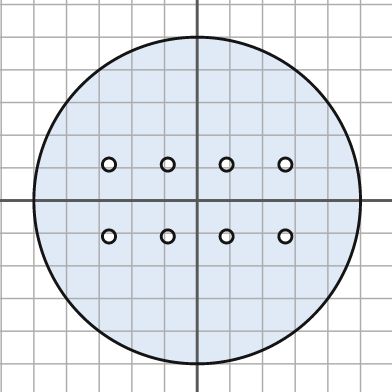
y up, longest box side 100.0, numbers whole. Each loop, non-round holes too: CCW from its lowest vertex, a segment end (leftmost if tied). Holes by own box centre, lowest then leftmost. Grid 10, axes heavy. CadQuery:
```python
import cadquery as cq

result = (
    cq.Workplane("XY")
    .moveTo(0.0, 0.0)
    .circle(50.0)
    .moveTo(-27.0, -11.0)
    .circle(2.0)
    .moveTo(-9.0, -11.0)
    .circle(2.0)
    .moveTo(9.0, -11.0)
    .circle(2.0)
    .moveTo(27.0, -11.0)
    .circle(2.0)
    .moveTo(-27.0, 11.0)
    .circle(2.0)
    .moveTo(-9.0, 11.0)
    .circle(2.0)
    .moveTo(9.0, 11.0)
    .circle(2.0)
    .moveTo(27.0, 11.0)
    .circle(2.0)
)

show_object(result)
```